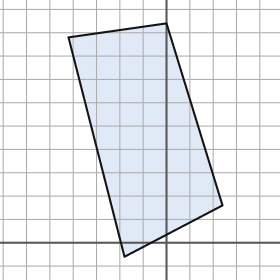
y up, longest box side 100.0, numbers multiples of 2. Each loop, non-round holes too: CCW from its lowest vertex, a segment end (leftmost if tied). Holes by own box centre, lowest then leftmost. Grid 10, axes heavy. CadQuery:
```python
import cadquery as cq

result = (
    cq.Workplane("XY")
    .moveTo(-18.0, -6.0)
    .lineTo(24.0, 16.0)
    .lineTo(0.0, 94.0)
    .lineTo(-42.0, 88.0)
    .close()
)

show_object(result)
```